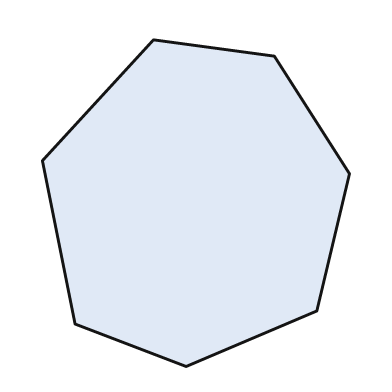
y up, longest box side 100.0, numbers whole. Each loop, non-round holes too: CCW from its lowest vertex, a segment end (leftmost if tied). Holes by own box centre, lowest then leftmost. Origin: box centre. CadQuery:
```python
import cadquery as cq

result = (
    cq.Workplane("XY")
    .moveTo(-3.0, -50.0)
    .lineTo(37.0, -33.0)
    .lineTo(47.0, 9.0)
    .lineTo(24.0, 45.0)
    .lineTo(-13.0, 50.0)
    .lineTo(-47.0, 13.0)
    .lineTo(-37.0, -37.0)
    .close()
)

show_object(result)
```